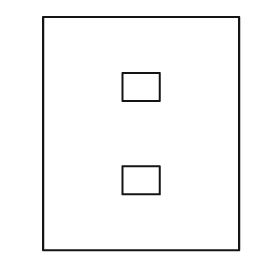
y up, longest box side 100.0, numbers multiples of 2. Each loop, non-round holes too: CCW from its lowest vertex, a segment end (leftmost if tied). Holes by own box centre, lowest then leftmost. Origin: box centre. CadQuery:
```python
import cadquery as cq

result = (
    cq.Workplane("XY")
    .moveTo(-42.0, -50.0)
    .lineTo(42.0, -50.0)
    .lineTo(42.0, 50.0)
    .lineTo(-42.0, 50.0)
    .close()
    .moveTo(-8.0, -26.0)
    .lineTo(8.0, -26.0)
    .lineTo(8.0, -14.0)
    .lineTo(-8.0, -14.0)
    .close()
    .moveTo(-8.0, 14.0)
    .lineTo(8.0, 14.0)
    .lineTo(8.0, 26.0)
    .lineTo(-8.0, 26.0)
    .close()
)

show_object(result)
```